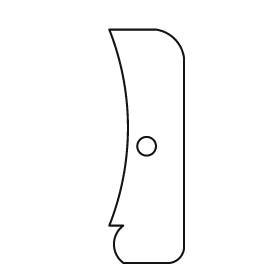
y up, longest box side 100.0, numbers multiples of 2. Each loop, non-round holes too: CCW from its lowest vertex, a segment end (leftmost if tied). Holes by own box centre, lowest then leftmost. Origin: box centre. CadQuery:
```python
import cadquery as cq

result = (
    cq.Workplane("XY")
    .moveTo(-10.0, -50.0)
    .lineTo(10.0, -50.0)
    .threePointArc((14.0, -48.0), (16.0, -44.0))
    .lineTo(16.0, 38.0)
    .threePointArc((12.0, 46.0), (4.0, 50.0))
    .lineTo(-16.0, 50.0)
    .threePointArc((-8.0, 8.0), (-16.0, -34.0))
    .lineTo(-10.0, -34.0)
    .threePointArc((-14.0, -42.0), (-10.0, -50.0))
    .close()
    .moveTo(0.0, 0.0)
    .circle(4.0)
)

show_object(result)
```